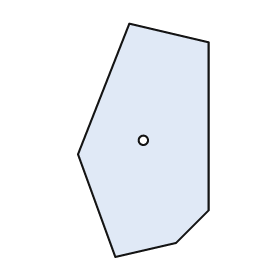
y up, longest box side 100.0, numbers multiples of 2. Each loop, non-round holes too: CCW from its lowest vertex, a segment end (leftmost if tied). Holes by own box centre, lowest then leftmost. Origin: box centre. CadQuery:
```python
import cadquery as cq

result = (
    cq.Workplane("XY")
    .moveTo(-12.0, -50.0)
    .lineTo(14.0, -44.0)
    .lineTo(28.0, -30.0)
    .lineTo(28.0, 42.0)
    .lineTo(-6.0, 50.0)
    .lineTo(-28.0, -6.0)
    .close()
    .moveTo(0.0, 0.0)
    .circle(2.0)
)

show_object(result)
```